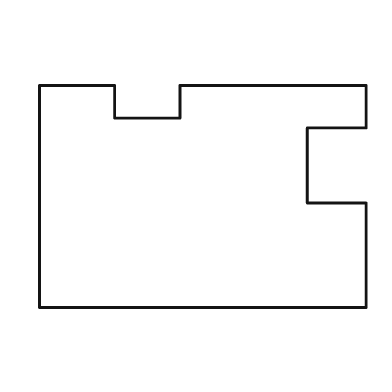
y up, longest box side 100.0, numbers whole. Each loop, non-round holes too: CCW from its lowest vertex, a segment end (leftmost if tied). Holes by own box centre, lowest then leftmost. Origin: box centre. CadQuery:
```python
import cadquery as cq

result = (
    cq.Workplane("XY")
    .moveTo(-50.0, -34.0)
    .lineTo(50.0, -34.0)
    .lineTo(50.0, -2.0)
    .lineTo(32.0, -2.0)
    .lineTo(32.0, 21.0)
    .lineTo(50.0, 21.0)
    .lineTo(50.0, 34.0)
    .lineTo(-7.0, 34.0)
    .lineTo(-7.0, 24.0)
    .lineTo(-27.0, 24.0)
    .lineTo(-27.0, 34.0)
    .lineTo(-50.0, 34.0)
    .close()
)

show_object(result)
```